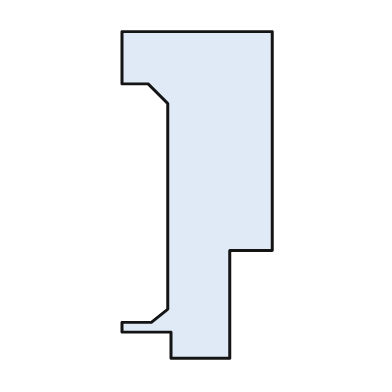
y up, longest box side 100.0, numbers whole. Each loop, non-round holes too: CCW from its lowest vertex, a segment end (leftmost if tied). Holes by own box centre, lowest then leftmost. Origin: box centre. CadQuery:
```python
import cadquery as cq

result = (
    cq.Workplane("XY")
    .moveTo(-8.0, -50.0)
    .lineTo(10.0, -50.0)
    .lineTo(10.0, -17.0)
    .lineTo(23.0, -17.0)
    .lineTo(23.0, 50.0)
    .lineTo(-23.0, 50.0)
    .lineTo(-23.0, 34.0)
    .lineTo(-15.0, 34.0)
    .lineTo(-9.0, 28.0)
    .lineTo(-9.0, -35.0)
    .lineTo(-14.0, -39.0)
    .lineTo(-23.0, -39.0)
    .lineTo(-23.0, -42.0)
    .lineTo(-8.0, -42.0)
    .close()
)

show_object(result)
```